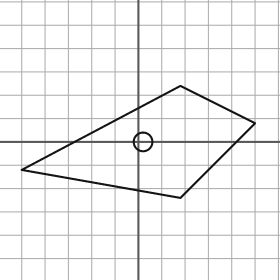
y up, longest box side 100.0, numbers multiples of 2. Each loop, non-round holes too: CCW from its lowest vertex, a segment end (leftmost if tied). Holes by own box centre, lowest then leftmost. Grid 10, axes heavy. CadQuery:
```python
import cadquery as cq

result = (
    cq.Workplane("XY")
    .moveTo(18.0, -24.0)
    .lineTo(50.0, 8.0)
    .lineTo(18.0, 24.0)
    .lineTo(-50.0, -12.0)
    .close()
    .moveTo(2.0, 0.0)
    .circle(4.0)
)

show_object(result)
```